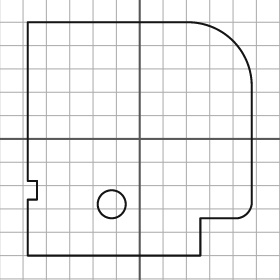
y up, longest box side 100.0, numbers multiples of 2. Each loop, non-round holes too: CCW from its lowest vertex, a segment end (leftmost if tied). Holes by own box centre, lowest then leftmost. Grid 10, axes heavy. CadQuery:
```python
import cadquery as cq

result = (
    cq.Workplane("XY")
    .moveTo(-48.0, -50.0)
    .lineTo(26.0, -50.0)
    .lineTo(26.0, -34.0)
    .lineTo(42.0, -34.0)
    .threePointArc((46.0, -32.0), (48.0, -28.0))
    .lineTo(48.0, 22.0)
    .threePointArc((40.0, 42.0), (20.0, 50.0))
    .lineTo(-48.0, 50.0)
    .lineTo(-48.0, -18.0)
    .lineTo(-44.0, -18.0)
    .lineTo(-44.0, -26.0)
    .lineTo(-48.0, -26.0)
    .close()
    .moveTo(-12.0, -28.0)
    .circle(6.0)
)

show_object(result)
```